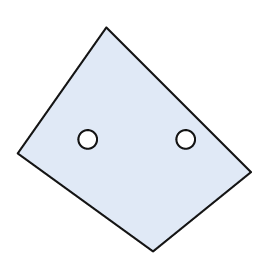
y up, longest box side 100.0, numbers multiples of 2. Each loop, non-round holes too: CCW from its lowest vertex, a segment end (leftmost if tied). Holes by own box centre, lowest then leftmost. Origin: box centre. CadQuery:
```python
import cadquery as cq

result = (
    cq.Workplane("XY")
    .moveTo(8.0, -48.0)
    .lineTo(50.0, -14.0)
    .lineTo(-12.0, 48.0)
    .lineTo(-50.0, -6.0)
    .close()
    .moveTo(-20.0, 0.0)
    .circle(4.0)
    .moveTo(22.0, 0.0)
    .circle(4.0)
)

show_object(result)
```